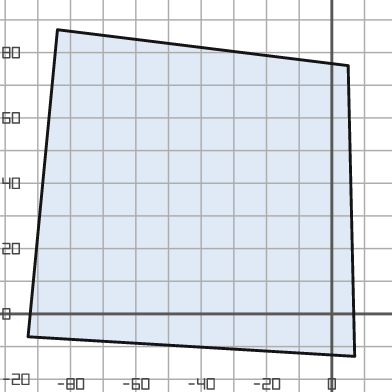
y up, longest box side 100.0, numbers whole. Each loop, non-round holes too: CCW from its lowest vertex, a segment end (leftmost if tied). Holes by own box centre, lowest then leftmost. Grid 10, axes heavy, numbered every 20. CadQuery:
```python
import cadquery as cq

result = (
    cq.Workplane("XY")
    .moveTo(7.0, -13.0)
    .lineTo(5.0, 76.0)
    .lineTo(-84.0, 87.0)
    .lineTo(-93.0, -7.0)
    .close()
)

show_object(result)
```